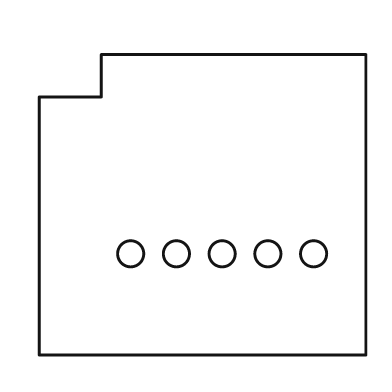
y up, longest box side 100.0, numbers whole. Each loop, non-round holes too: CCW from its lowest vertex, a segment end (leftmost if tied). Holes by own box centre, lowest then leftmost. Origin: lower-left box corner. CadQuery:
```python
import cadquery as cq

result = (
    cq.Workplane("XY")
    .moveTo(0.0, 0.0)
    .lineTo(100.0, 0.0)
    .lineTo(100.0, 92.0)
    .lineTo(19.0, 92.0)
    .lineTo(19.0, 79.0)
    .lineTo(0.0, 79.0)
    .close()
    .moveTo(28.0, 31.0)
    .circle(4.0)
    .moveTo(42.0, 31.0)
    .circle(4.0)
    .moveTo(56.0, 31.0)
    .circle(4.0)
    .moveTo(70.0, 31.0)
    .circle(4.0)
    .moveTo(84.0, 31.0)
    .circle(4.0)
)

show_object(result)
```